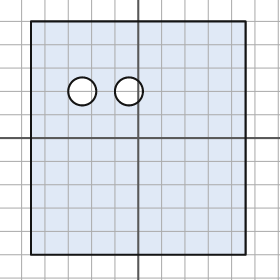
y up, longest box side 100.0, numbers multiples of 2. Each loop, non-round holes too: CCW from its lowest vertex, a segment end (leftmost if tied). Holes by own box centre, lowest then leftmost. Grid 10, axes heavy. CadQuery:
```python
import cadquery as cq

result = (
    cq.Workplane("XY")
    .moveTo(-46.0, -50.0)
    .lineTo(46.0, -50.0)
    .lineTo(46.0, 50.0)
    .lineTo(-46.0, 50.0)
    .close()
    .moveTo(-24.0, 20.0)
    .circle(6.0)
    .moveTo(-4.0, 20.0)
    .circle(6.0)
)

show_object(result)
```